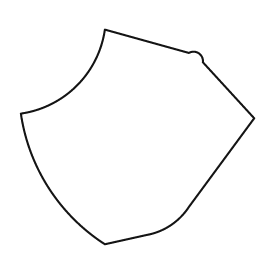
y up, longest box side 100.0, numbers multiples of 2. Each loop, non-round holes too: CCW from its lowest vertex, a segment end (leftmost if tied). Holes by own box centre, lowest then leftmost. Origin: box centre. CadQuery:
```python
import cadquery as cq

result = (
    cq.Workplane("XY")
    .moveTo(-14.0, -46.0)
    .lineTo(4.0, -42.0)
    .threePointArc((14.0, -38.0), (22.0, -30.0))
    .lineTo(50.0, 8.0)
    .lineTo(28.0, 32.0)
    .threePointArc((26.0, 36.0), (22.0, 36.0))
    .lineTo(-14.0, 46.0)
    .threePointArc((-26.0, 22.0), (-50.0, 10.0))
    .threePointArc((-38.0, -22.0), (-14.0, -46.0))
    .close()
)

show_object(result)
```